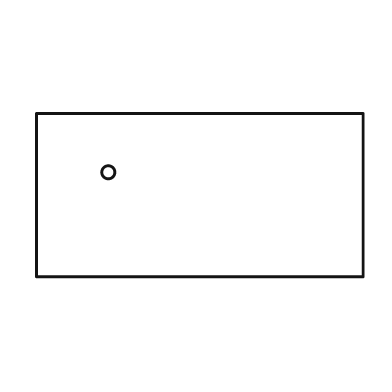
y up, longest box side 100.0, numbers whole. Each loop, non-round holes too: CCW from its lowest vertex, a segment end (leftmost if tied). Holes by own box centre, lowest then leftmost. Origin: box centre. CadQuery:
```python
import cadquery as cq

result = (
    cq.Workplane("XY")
    .moveTo(-50.0, -25.0)
    .lineTo(50.0, -25.0)
    .lineTo(50.0, 25.0)
    .lineTo(-50.0, 25.0)
    .close()
    .moveTo(-28.0, 7.0)
    .circle(2.0)
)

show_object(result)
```